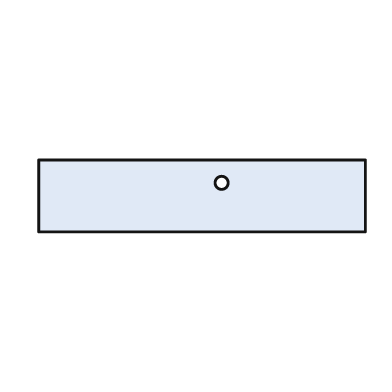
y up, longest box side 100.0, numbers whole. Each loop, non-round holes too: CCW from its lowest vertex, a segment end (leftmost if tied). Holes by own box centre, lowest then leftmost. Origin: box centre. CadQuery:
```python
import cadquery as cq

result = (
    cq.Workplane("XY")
    .moveTo(-50.0, -11.0)
    .lineTo(50.0, -11.0)
    .lineTo(50.0, 11.0)
    .lineTo(-50.0, 11.0)
    .close()
    .moveTo(6.0, 4.0)
    .circle(2.0)
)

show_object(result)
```